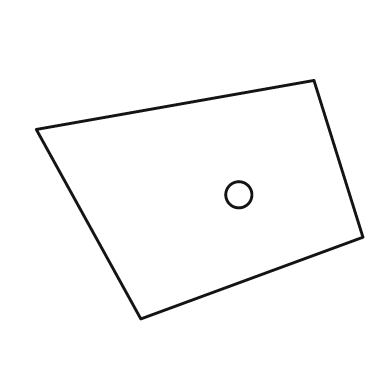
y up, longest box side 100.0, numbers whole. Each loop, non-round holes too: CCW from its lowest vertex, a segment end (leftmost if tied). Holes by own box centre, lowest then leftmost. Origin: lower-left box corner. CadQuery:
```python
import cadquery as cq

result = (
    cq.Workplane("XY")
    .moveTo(32.0, 0.0)
    .lineTo(100.0, 25.0)
    .lineTo(85.0, 73.0)
    .lineTo(0.0, 58.0)
    .close()
    .moveTo(62.0, 38.0)
    .circle(4.0)
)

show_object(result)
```